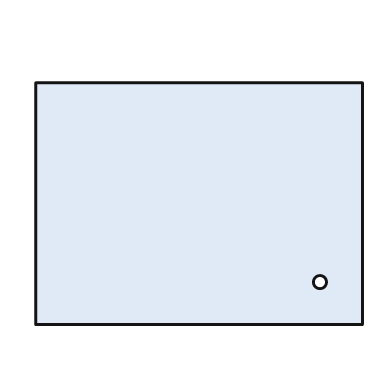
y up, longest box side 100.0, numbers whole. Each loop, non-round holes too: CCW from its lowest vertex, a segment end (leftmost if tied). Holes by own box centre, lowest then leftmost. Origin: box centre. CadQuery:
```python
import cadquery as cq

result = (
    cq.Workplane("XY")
    .moveTo(-50.0, -37.0)
    .lineTo(50.0, -37.0)
    .lineTo(50.0, 37.0)
    .lineTo(-50.0, 37.0)
    .close()
    .moveTo(37.0, -24.0)
    .circle(2.0)
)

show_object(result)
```